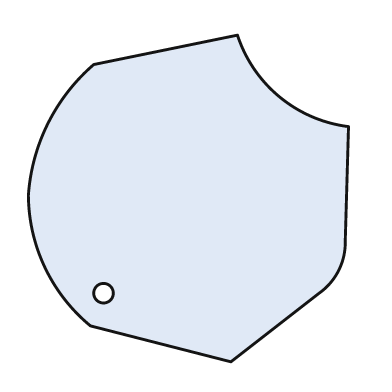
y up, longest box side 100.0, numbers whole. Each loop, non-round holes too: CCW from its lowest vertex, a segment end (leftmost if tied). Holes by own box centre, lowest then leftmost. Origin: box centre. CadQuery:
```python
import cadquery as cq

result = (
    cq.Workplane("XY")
    .moveTo(13.0, -50.0)
    .lineTo(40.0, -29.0)
    .threePointArc((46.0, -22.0), (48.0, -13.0))
    .lineTo(49.0, 22.0)
    .threePointArc((28.0, 31.0), (15.0, 50.0))
    .lineTo(-29.0, 41.0)
    .threePointArc((-43.0, 23.0), (-49.0, 1.0))
    .threePointArc((-44.0, -21.0), (-30.0, -39.0))
    .close()
    .moveTo(-26.0, -29.0)
    .circle(3.0)
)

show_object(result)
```